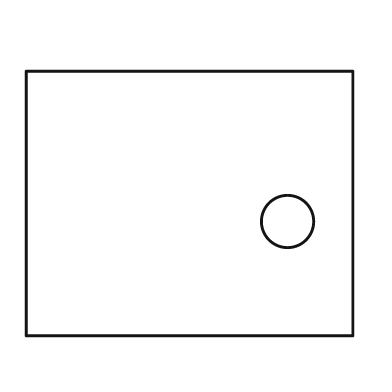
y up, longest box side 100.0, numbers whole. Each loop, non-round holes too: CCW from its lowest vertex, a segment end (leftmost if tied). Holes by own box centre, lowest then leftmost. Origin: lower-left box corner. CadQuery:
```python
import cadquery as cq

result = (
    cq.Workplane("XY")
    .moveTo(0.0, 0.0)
    .lineTo(100.0, 0.0)
    .lineTo(100.0, 81.0)
    .lineTo(0.0, 81.0)
    .close()
    .moveTo(80.0, 35.0)
    .circle(8.0)
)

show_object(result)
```